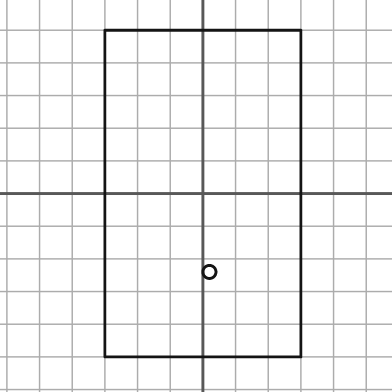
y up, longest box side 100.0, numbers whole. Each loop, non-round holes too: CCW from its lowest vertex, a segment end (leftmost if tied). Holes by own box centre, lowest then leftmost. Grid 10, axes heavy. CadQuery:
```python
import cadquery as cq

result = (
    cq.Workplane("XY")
    .moveTo(-30.0, -50.0)
    .lineTo(30.0, -50.0)
    .lineTo(30.0, 50.0)
    .lineTo(-30.0, 50.0)
    .close()
    .moveTo(2.0, -24.0)
    .circle(2.0)
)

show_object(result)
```